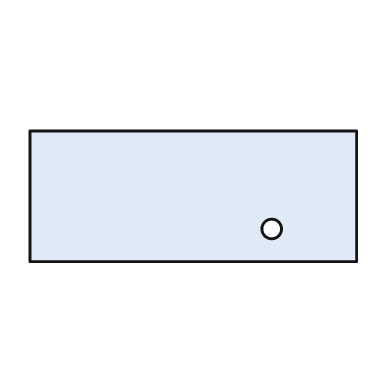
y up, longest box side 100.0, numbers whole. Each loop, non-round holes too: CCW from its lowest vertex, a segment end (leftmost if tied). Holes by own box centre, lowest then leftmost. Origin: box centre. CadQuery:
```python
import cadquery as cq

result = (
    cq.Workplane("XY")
    .moveTo(-50.0, -20.0)
    .lineTo(50.0, -20.0)
    .lineTo(50.0, 20.0)
    .lineTo(-50.0, 20.0)
    .close()
    .moveTo(24.0, -10.0)
    .circle(3.0)
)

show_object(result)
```